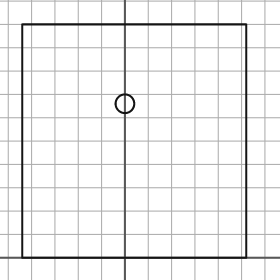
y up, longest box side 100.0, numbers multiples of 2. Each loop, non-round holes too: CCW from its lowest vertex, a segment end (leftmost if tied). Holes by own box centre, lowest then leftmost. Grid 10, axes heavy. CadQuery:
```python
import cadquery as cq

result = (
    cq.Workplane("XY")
    .moveTo(-44.0, 0.0)
    .lineTo(52.0, 0.0)
    .lineTo(52.0, 100.0)
    .lineTo(-44.0, 100.0)
    .close()
    .moveTo(0.0, 66.0)
    .circle(4.0)
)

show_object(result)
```